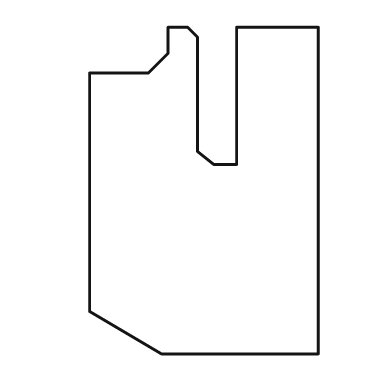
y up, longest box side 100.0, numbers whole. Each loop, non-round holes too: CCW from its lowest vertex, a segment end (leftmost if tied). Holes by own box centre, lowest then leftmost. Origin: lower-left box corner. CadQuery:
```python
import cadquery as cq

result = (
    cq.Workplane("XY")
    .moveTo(22.0, 0.0)
    .lineTo(70.0, 0.0)
    .lineTo(70.0, 100.0)
    .lineTo(45.0, 100.0)
    .lineTo(45.0, 58.0)
    .lineTo(38.0, 58.0)
    .lineTo(33.0, 62.0)
    .lineTo(33.0, 97.0)
    .lineTo(30.0, 100.0)
    .lineTo(24.0, 100.0)
    .lineTo(24.0, 92.0)
    .lineTo(18.0, 86.0)
    .lineTo(0.0, 86.0)
    .lineTo(0.0, 13.0)
    .close()
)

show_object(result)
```